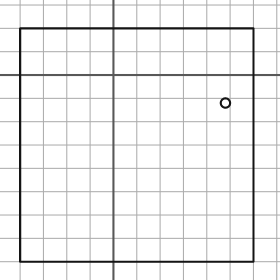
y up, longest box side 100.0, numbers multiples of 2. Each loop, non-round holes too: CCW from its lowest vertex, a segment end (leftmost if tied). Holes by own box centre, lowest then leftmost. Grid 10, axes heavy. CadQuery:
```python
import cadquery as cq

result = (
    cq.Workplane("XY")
    .moveTo(-40.0, -80.0)
    .lineTo(60.0, -80.0)
    .lineTo(60.0, 20.0)
    .lineTo(-40.0, 20.0)
    .close()
    .moveTo(48.0, -12.0)
    .circle(2.0)
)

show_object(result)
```